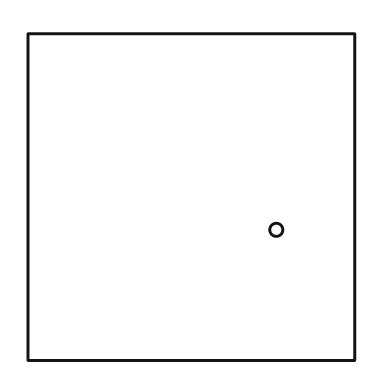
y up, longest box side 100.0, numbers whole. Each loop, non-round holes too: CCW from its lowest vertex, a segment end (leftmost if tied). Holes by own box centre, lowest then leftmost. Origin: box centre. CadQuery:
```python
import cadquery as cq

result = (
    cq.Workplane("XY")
    .moveTo(-50.0, -50.0)
    .lineTo(50.0, -50.0)
    .lineTo(50.0, 50.0)
    .lineTo(-50.0, 50.0)
    .close()
    .moveTo(26.0, -10.0)
    .circle(2.0)
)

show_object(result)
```